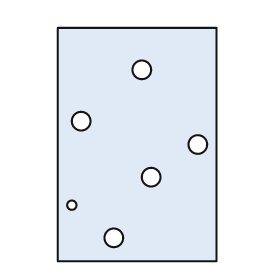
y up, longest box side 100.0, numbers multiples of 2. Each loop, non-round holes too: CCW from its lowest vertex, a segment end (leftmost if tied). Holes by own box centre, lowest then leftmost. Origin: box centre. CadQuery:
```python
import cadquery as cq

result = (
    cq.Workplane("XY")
    .moveTo(-34.0, -50.0)
    .lineTo(34.0, -50.0)
    .lineTo(34.0, 50.0)
    .lineTo(-34.0, 50.0)
    .close()
    .moveTo(-10.0, -40.0)
    .circle(4.0)
    .moveTo(-28.0, -26.0)
    .circle(2.0)
    .moveTo(6.0, -14.0)
    .circle(4.0)
    .moveTo(26.0, 0.0)
    .circle(4.0)
    .moveTo(-24.0, 10.0)
    .circle(4.0)
    .moveTo(2.0, 32.0)
    .circle(4.0)
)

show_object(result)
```